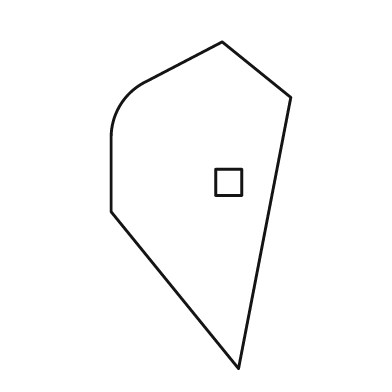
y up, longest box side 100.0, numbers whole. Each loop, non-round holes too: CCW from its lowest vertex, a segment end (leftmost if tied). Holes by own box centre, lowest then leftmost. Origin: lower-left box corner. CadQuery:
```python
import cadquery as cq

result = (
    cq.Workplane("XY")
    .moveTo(39.0, 0.0)
    .lineTo(55.0, 83.0)
    .lineTo(34.0, 100.0)
    .lineTo(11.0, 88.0)
    .threePointArc((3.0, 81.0), (0.0, 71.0))
    .lineTo(0.0, 48.0)
    .close()
    .moveTo(32.0, 53.0)
    .lineTo(40.0, 53.0)
    .lineTo(40.0, 61.0)
    .lineTo(32.0, 61.0)
    .close()
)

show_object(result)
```